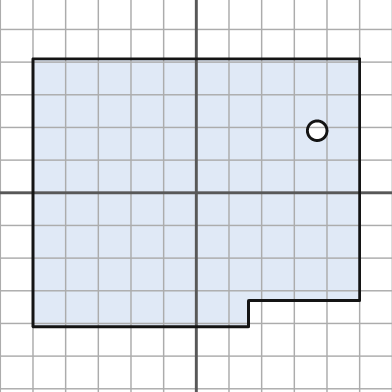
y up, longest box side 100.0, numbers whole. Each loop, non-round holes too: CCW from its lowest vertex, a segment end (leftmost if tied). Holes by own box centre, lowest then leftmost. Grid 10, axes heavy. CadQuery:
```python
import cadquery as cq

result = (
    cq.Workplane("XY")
    .moveTo(-50.0, -41.0)
    .lineTo(16.0, -41.0)
    .lineTo(16.0, -33.0)
    .lineTo(50.0, -33.0)
    .lineTo(50.0, 41.0)
    .lineTo(-50.0, 41.0)
    .close()
    .moveTo(37.0, 19.0)
    .circle(3.0)
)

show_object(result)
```